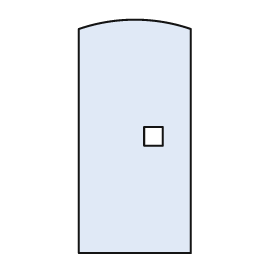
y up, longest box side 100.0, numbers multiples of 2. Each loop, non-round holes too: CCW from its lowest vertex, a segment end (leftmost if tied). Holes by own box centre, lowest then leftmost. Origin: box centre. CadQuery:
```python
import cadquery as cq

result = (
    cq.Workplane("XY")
    .moveTo(-24.0, -50.0)
    .lineTo(24.0, -50.0)
    .lineTo(24.0, 46.0)
    .threePointArc((0.0, 50.0), (-24.0, 46.0))
    .close()
    .moveTo(4.0, -4.0)
    .lineTo(12.0, -4.0)
    .lineTo(12.0, 4.0)
    .lineTo(4.0, 4.0)
    .close()
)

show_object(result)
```